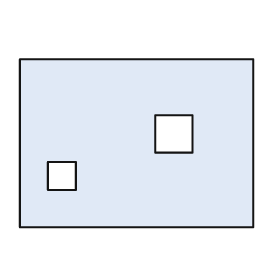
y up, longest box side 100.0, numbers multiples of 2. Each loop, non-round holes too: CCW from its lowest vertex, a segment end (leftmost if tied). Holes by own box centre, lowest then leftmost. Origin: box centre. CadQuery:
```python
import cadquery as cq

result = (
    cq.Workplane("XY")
    .moveTo(-50.0, -36.0)
    .lineTo(50.0, -36.0)
    .lineTo(50.0, 36.0)
    .lineTo(-50.0, 36.0)
    .close()
    .moveTo(-38.0, -20.0)
    .lineTo(-26.0, -20.0)
    .lineTo(-26.0, -8.0)
    .lineTo(-38.0, -8.0)
    .close()
    .moveTo(8.0, -4.0)
    .lineTo(24.0, -4.0)
    .lineTo(24.0, 12.0)
    .lineTo(8.0, 12.0)
    .close()
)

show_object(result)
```